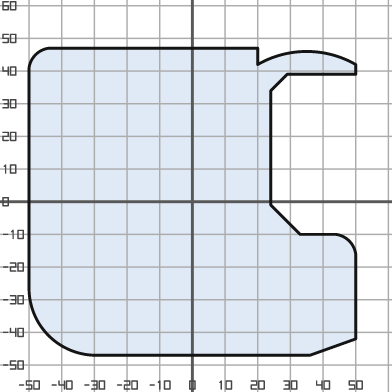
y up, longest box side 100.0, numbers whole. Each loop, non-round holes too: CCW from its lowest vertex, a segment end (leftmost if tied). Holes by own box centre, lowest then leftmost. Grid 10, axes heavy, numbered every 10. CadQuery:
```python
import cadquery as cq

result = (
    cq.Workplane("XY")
    .moveTo(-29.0, -47.0)
    .lineTo(36.0, -47.0)
    .lineTo(50.0, -42.0)
    .lineTo(50.0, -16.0)
    .threePointArc((48.0, -12.0), (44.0, -10.0))
    .lineTo(33.0, -10.0)
    .lineTo(24.0, -1.0)
    .lineTo(24.0, 34.0)
    .lineTo(29.0, 39.0)
    .lineTo(50.0, 39.0)
    .lineTo(50.0, 42.0)
    .threePointArc((35.0, 46.0), (20.0, 42.0))
    .lineTo(20.0, 47.0)
    .lineTo(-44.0, 47.0)
    .threePointArc((-48.0, 45.0), (-50.0, 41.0))
    .lineTo(-50.0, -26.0)
    .threePointArc((-44.0, -41.0), (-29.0, -47.0))
    .close()
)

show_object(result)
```